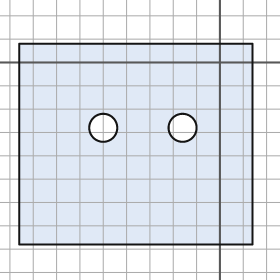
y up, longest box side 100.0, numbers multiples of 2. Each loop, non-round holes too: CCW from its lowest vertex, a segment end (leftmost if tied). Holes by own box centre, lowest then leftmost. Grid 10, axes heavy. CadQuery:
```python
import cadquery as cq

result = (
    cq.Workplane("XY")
    .moveTo(-86.0, -78.0)
    .lineTo(14.0, -78.0)
    .lineTo(14.0, 8.0)
    .lineTo(-86.0, 8.0)
    .close()
    .moveTo(-50.0, -28.0)
    .circle(6.0)
    .moveTo(-16.0, -28.0)
    .circle(6.0)
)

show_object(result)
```